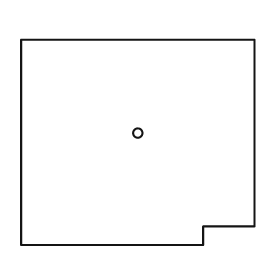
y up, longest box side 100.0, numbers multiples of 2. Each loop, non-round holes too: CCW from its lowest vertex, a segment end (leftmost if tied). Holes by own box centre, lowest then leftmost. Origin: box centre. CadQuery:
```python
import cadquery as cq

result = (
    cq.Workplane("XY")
    .moveTo(-50.0, -44.0)
    .lineTo(28.0, -44.0)
    .lineTo(28.0, -36.0)
    .lineTo(50.0, -36.0)
    .lineTo(50.0, 44.0)
    .lineTo(-50.0, 44.0)
    .close()
    .moveTo(0.0, 4.0)
    .circle(2.0)
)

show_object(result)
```